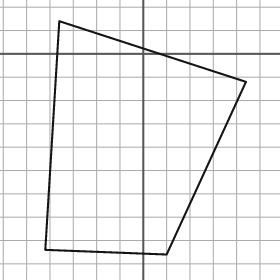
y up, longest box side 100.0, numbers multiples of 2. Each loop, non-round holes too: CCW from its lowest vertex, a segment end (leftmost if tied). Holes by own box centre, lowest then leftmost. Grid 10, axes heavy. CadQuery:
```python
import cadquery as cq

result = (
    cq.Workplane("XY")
    .moveTo(10.0, -86.0)
    .lineTo(44.0, -12.0)
    .lineTo(-36.0, 14.0)
    .lineTo(-42.0, -84.0)
    .close()
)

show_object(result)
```